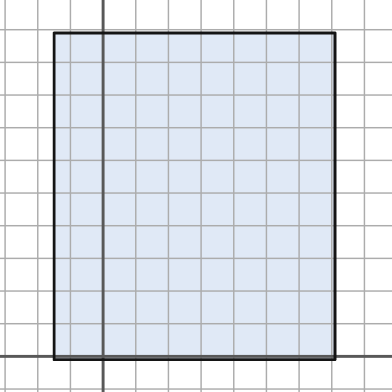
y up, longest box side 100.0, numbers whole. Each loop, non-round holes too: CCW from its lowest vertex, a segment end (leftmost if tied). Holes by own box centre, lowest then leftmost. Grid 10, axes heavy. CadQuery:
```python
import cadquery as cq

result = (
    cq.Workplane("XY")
    .moveTo(-15.0, -1.0)
    .lineTo(71.0, -1.0)
    .lineTo(71.0, 99.0)
    .lineTo(-15.0, 99.0)
    .close()
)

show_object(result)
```